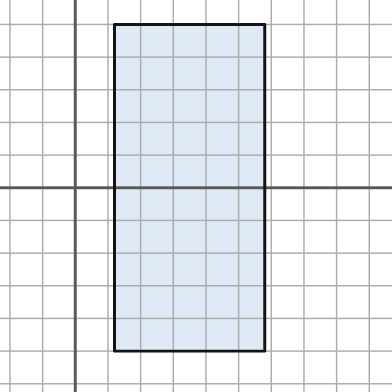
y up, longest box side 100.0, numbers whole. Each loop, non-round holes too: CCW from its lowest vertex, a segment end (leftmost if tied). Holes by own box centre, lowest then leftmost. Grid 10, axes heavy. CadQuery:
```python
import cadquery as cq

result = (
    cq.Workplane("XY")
    .moveTo(12.0, -50.0)
    .lineTo(58.0, -50.0)
    .lineTo(58.0, 50.0)
    .lineTo(12.0, 50.0)
    .close()
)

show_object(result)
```